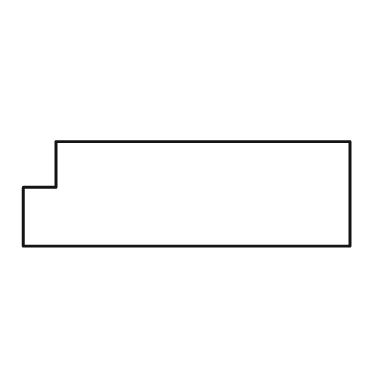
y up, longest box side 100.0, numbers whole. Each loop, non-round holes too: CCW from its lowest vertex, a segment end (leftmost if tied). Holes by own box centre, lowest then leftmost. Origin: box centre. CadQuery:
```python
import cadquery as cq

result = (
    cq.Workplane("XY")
    .moveTo(-50.0, -16.0)
    .lineTo(50.0, -16.0)
    .lineTo(50.0, 16.0)
    .lineTo(-40.0, 16.0)
    .lineTo(-40.0, 2.0)
    .lineTo(-50.0, 2.0)
    .close()
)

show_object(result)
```